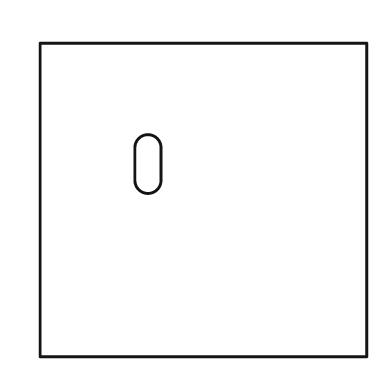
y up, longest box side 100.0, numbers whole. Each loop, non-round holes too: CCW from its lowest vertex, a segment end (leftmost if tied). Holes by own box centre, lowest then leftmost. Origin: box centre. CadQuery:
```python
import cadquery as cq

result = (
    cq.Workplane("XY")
    .moveTo(-50.0, -48.0)
    .lineTo(50.0, -48.0)
    .lineTo(50.0, 48.0)
    .lineTo(-50.0, 48.0)
    .close()
    .moveTo(-21.0, 6.0)
    .threePointArc((-17.0, 2.0), (-13.0, 6.0))
    .lineTo(-13.0, 16.0)
    .threePointArc((-17.0, 20.0), (-21.0, 16.0))
    .close()
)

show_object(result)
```